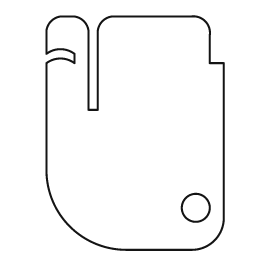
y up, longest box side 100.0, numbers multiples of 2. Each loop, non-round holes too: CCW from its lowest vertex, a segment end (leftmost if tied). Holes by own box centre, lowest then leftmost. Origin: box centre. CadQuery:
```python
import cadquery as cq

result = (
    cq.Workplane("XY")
    .moveTo(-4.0, -50.0)
    .lineTo(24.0, -50.0)
    .threePointArc((34.0, -46.0), (38.0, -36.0))
    .lineTo(38.0, 30.0)
    .lineTo(32.0, 30.0)
    .lineTo(32.0, 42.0)
    .threePointArc((30.0, 48.0), (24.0, 50.0))
    .lineTo(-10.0, 50.0)
    .threePointArc((-14.0, 48.0), (-16.0, 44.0))
    .lineTo(-16.0, 10.0)
    .lineTo(-20.0, 10.0)
    .lineTo(-20.0, 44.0)
    .threePointArc((-22.0, 48.0), (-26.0, 50.0))
    .lineTo(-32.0, 50.0)
    .threePointArc((-36.0, 48.0), (-38.0, 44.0))
    .lineTo(-38.0, 34.0)
    .threePointArc((-32.0, 36.0), (-26.0, 34.0))
    .lineTo(-26.0, 30.0)
    .threePointArc((-32.0, 32.0), (-38.0, 30.0))
    .lineTo(-38.0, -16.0)
    .threePointArc((-28.0, -40.0), (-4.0, -50.0))
    .close()
    .moveTo(26.0, -32.0)
    .circle(6.0)
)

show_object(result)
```